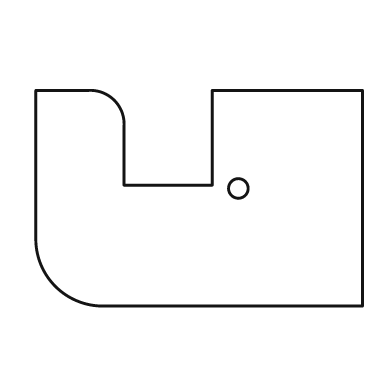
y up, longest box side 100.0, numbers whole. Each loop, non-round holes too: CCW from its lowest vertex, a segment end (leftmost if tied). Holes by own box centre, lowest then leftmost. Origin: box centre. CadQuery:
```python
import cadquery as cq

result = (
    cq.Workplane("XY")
    .moveTo(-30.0, -33.0)
    .lineTo(50.0, -33.0)
    .lineTo(50.0, 33.0)
    .lineTo(4.0, 33.0)
    .lineTo(4.0, 4.0)
    .lineTo(-23.0, 4.0)
    .lineTo(-23.0, 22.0)
    .threePointArc((-26.0, 30.0), (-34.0, 33.0))
    .lineTo(-50.0, 33.0)
    .lineTo(-50.0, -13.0)
    .threePointArc((-44.0, -27.0), (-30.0, -33.0))
    .close()
    .moveTo(12.0, 3.0)
    .circle(3.0)
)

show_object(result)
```